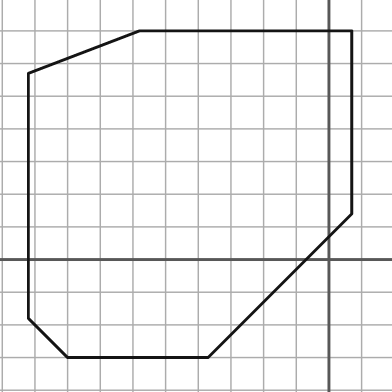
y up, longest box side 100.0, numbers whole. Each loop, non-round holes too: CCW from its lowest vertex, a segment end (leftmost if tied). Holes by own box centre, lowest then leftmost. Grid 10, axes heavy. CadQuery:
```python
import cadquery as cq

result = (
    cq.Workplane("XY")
    .moveTo(-80.0, -30.0)
    .lineTo(-37.0, -30.0)
    .lineTo(7.0, 14.0)
    .lineTo(7.0, 70.0)
    .lineTo(-58.0, 70.0)
    .lineTo(-92.0, 57.0)
    .lineTo(-92.0, -18.0)
    .close()
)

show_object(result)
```